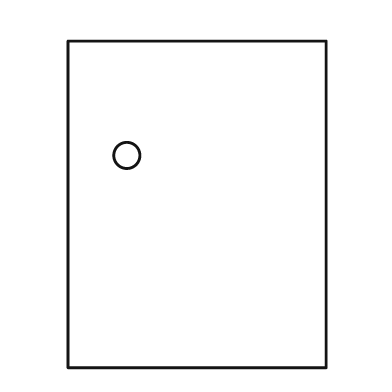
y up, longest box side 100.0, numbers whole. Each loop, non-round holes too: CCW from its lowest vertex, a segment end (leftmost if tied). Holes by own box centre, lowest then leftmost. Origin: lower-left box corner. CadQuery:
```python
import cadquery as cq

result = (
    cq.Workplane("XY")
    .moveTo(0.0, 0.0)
    .lineTo(79.0, 0.0)
    .lineTo(79.0, 100.0)
    .lineTo(0.0, 100.0)
    .close()
    .moveTo(18.0, 65.0)
    .circle(4.0)
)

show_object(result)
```